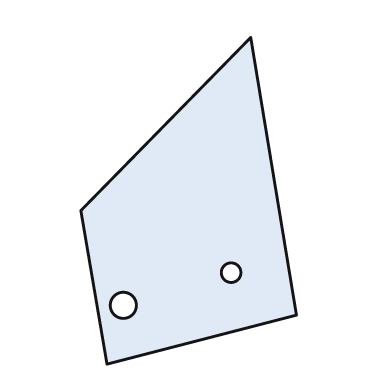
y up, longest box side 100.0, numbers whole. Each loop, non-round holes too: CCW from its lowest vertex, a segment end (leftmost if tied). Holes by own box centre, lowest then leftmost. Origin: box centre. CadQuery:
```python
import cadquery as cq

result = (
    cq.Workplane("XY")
    .moveTo(-25.0, -50.0)
    .lineTo(33.0, -35.0)
    .lineTo(19.0, 50.0)
    .lineTo(-33.0, -3.0)
    .close()
    .moveTo(-20.0, -32.0)
    .circle(4.0)
    .moveTo(13.0, -22.0)
    .circle(3.0)
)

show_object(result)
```